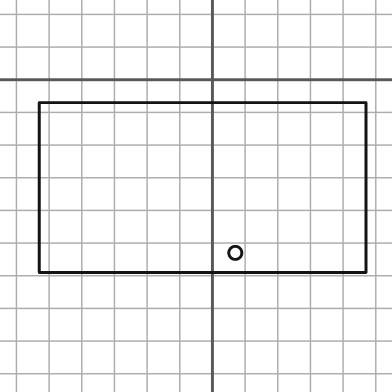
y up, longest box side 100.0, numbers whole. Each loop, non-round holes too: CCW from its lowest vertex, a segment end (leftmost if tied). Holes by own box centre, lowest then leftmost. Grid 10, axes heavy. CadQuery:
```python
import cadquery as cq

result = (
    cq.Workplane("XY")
    .moveTo(-53.0, -59.0)
    .lineTo(47.0, -59.0)
    .lineTo(47.0, -7.0)
    .lineTo(-53.0, -7.0)
    .close()
    .moveTo(7.0, -53.0)
    .circle(2.0)
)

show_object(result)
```